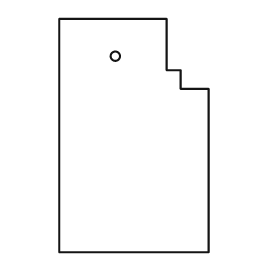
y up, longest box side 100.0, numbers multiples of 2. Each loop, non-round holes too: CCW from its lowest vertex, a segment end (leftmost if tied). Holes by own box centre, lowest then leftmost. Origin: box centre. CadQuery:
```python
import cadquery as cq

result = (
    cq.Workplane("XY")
    .moveTo(-32.0, -50.0)
    .lineTo(32.0, -50.0)
    .lineTo(32.0, 20.0)
    .lineTo(20.0, 20.0)
    .lineTo(20.0, 28.0)
    .lineTo(14.0, 28.0)
    .lineTo(14.0, 50.0)
    .lineTo(-32.0, 50.0)
    .close()
    .moveTo(-8.0, 34.0)
    .circle(2.0)
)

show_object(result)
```